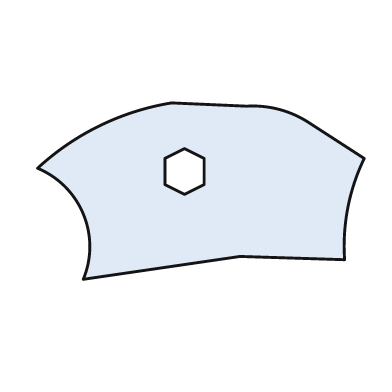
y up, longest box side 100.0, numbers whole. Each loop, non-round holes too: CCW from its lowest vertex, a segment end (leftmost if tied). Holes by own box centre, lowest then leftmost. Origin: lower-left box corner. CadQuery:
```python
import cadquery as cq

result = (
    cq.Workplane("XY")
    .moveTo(14.0, 0.0)
    .lineTo(62.0, 7.0)
    .lineTo(94.0, 6.0)
    .threePointArc((95.0, 22.0), (100.0, 37.0))
    .lineTo(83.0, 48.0)
    .threePointArc((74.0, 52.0), (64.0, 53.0))
    .lineTo(41.0, 54.0)
    .threePointArc((19.0, 47.0), (0.0, 34.0))
    .threePointArc((14.0, 20.0), (14.0, 0.0))
    .close()
    .moveTo(45.0, 26.0)
    .lineTo(51.0, 29.0)
    .lineTo(51.0, 37.0)
    .lineTo(45.0, 40.0)
    .lineTo(39.0, 37.0)
    .lineTo(39.0, 29.0)
    .close()
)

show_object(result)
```